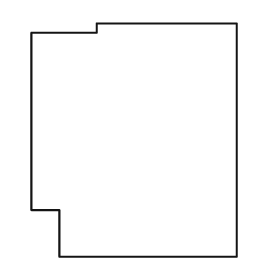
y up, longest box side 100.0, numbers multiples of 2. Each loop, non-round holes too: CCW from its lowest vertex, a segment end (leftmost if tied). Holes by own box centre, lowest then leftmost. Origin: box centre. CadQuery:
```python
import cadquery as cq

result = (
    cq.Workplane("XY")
    .moveTo(-32.0, -50.0)
    .lineTo(44.0, -50.0)
    .lineTo(44.0, 50.0)
    .lineTo(-16.0, 50.0)
    .lineTo(-16.0, 46.0)
    .lineTo(-44.0, 46.0)
    .lineTo(-44.0, -30.0)
    .lineTo(-32.0, -30.0)
    .close()
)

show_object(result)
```